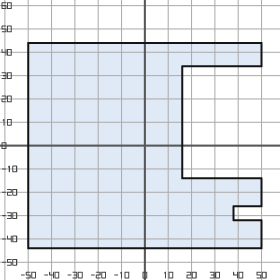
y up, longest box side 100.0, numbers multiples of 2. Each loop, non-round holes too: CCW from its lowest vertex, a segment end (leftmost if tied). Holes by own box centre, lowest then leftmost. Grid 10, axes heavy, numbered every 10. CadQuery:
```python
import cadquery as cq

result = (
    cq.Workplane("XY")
    .moveTo(-50.0, -44.0)
    .lineTo(50.0, -44.0)
    .lineTo(50.0, -32.0)
    .lineTo(38.0, -32.0)
    .lineTo(38.0, -26.0)
    .lineTo(50.0, -26.0)
    .lineTo(50.0, -14.0)
    .lineTo(16.0, -14.0)
    .lineTo(16.0, 34.0)
    .lineTo(50.0, 34.0)
    .lineTo(50.0, 44.0)
    .lineTo(-50.0, 44.0)
    .close()
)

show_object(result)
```